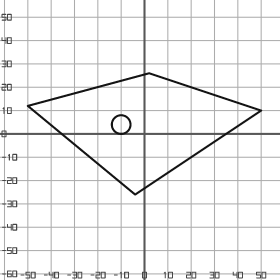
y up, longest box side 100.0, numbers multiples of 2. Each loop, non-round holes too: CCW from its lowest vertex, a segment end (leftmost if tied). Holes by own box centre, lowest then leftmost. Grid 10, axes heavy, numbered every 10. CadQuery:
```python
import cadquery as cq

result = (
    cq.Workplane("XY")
    .moveTo(-4.0, -26.0)
    .lineTo(50.0, 10.0)
    .lineTo(2.0, 26.0)
    .lineTo(-50.0, 12.0)
    .close()
    .moveTo(-10.0, 4.0)
    .circle(4.0)
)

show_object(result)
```